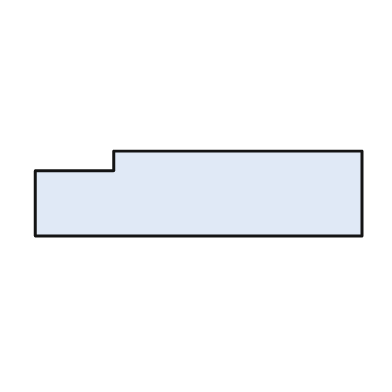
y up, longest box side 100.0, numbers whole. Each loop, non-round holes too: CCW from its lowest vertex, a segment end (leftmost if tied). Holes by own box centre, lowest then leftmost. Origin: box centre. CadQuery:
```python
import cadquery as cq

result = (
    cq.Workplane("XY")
    .moveTo(-50.0, -13.0)
    .lineTo(50.0, -13.0)
    .lineTo(50.0, 13.0)
    .lineTo(-26.0, 13.0)
    .lineTo(-26.0, 7.0)
    .lineTo(-50.0, 7.0)
    .close()
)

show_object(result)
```